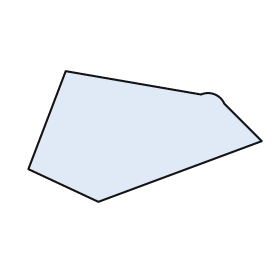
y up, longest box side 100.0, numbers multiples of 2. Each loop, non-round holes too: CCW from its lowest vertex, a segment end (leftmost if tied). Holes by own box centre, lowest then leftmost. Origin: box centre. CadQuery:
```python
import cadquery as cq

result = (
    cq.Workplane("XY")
    .moveTo(-20.0, -28.0)
    .lineTo(50.0, -2.0)
    .lineTo(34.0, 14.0)
    .threePointArc((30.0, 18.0), (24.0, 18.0))
    .lineTo(-34.0, 28.0)
    .lineTo(-50.0, -14.0)
    .close()
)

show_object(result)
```